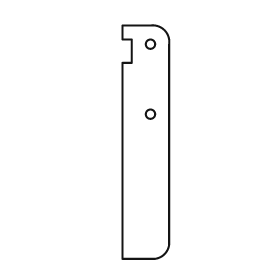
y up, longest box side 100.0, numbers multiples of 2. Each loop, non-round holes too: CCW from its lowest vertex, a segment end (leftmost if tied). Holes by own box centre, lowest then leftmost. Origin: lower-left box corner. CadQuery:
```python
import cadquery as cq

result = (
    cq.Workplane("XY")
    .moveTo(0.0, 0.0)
    .lineTo(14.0, 0.0)
    .threePointArc((18.0, 2.0), (20.0, 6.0))
    .lineTo(20.0, 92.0)
    .threePointArc((18.0, 98.0), (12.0, 100.0))
    .lineTo(0.0, 100.0)
    .lineTo(0.0, 94.0)
    .lineTo(4.0, 94.0)
    .lineTo(4.0, 84.0)
    .lineTo(0.0, 84.0)
    .close()
    .moveTo(12.0, 62.0)
    .circle(2.0)
    .moveTo(12.0, 92.0)
    .circle(2.0)
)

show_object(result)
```